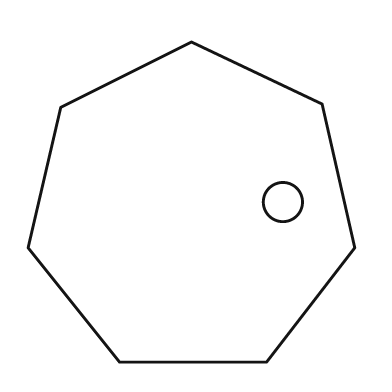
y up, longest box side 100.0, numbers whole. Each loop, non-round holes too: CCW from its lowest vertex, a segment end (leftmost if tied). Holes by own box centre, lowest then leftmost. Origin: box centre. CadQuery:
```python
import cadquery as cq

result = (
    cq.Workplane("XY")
    .moveTo(-22.0, -49.0)
    .lineTo(23.0, -49.0)
    .lineTo(50.0, -14.0)
    .lineTo(40.0, 30.0)
    .lineTo(0.0, 49.0)
    .lineTo(-40.0, 29.0)
    .lineTo(-50.0, -14.0)
    .close()
    .moveTo(28.0, 0.0)
    .circle(6.0)
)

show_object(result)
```